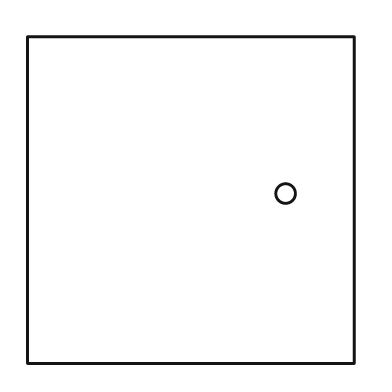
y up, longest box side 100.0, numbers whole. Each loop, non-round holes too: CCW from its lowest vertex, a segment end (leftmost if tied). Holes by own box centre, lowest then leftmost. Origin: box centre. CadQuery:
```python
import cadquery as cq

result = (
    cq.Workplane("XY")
    .moveTo(-50.0, -50.0)
    .lineTo(50.0, -50.0)
    .lineTo(50.0, 50.0)
    .lineTo(-50.0, 50.0)
    .close()
    .moveTo(29.0, 2.0)
    .circle(3.0)
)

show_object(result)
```